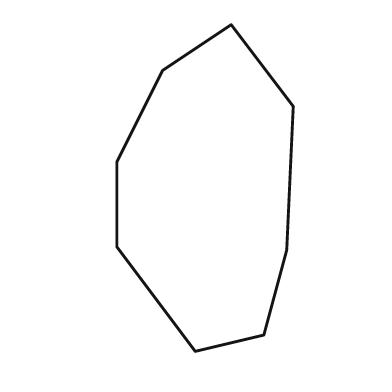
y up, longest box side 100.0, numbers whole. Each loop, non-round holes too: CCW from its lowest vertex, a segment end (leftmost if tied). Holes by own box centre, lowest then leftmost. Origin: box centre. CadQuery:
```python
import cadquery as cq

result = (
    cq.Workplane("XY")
    .moveTo(-3.0, -50.0)
    .lineTo(18.0, -45.0)
    .lineTo(25.0, -19.0)
    .lineTo(27.0, 25.0)
    .lineTo(8.0, 50.0)
    .lineTo(-13.0, 36.0)
    .lineTo(-27.0, 8.0)
    .lineTo(-27.0, -18.0)
    .close()
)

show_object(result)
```